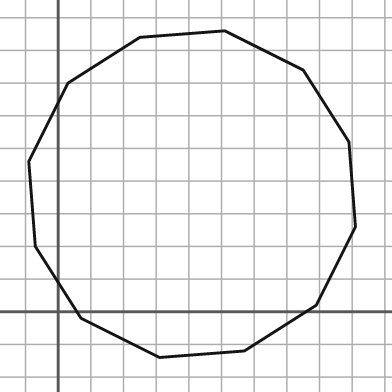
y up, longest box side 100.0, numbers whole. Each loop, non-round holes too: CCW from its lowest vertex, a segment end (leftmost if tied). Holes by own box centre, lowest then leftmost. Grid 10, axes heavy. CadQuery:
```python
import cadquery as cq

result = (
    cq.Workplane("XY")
    .moveTo(31.0, -14.0)
    .lineTo(57.0, -12.0)
    .lineTo(79.0, 2.0)
    .lineTo(91.0, 26.0)
    .lineTo(89.0, 52.0)
    .lineTo(75.0, 74.0)
    .lineTo(51.0, 86.0)
    .lineTo(25.0, 84.0)
    .lineTo(3.0, 70.0)
    .lineTo(-9.0, 46.0)
    .lineTo(-7.0, 20.0)
    .lineTo(7.0, -2.0)
    .close()
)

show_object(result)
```